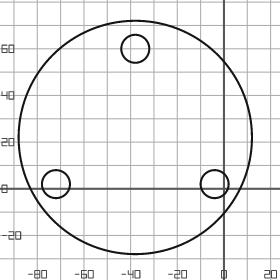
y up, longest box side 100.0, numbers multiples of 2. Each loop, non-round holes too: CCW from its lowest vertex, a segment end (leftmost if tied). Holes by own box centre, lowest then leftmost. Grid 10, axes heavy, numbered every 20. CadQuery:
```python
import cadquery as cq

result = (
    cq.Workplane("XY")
    .moveTo(-38.0, 22.0)
    .circle(50.0)
    .moveTo(-72.0, 2.0)
    .circle(6.0)
    .moveTo(-4.0, 2.0)
    .circle(6.0)
    .moveTo(-38.0, 60.0)
    .circle(6.0)
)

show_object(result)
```